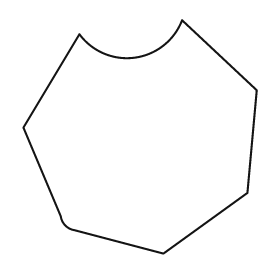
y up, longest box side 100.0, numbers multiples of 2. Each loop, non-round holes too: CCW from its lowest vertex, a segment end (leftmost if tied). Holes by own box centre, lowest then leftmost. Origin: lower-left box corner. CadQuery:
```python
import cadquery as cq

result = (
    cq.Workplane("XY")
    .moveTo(60.0, 0.0)
    .lineTo(96.0, 26.0)
    .lineTo(100.0, 70.0)
    .lineTo(68.0, 100.0)
    .threePointArc((48.0, 84.0), (24.0, 94.0))
    .lineTo(0.0, 54.0)
    .lineTo(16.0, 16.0)
    .threePointArc((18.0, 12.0), (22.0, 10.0))
    .close()
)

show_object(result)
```